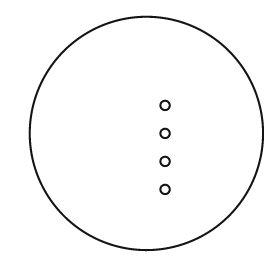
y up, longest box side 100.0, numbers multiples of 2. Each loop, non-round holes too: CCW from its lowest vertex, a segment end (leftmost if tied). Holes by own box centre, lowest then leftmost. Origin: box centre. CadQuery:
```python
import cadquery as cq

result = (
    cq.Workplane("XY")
    .moveTo(0.0, 0.0)
    .circle(50.0)
    .moveTo(8.0, -24.0)
    .circle(2.0)
    .moveTo(8.0, -12.0)
    .circle(2.0)
    .moveTo(8.0, 0.0)
    .circle(2.0)
    .moveTo(8.0, 12.0)
    .circle(2.0)
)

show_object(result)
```